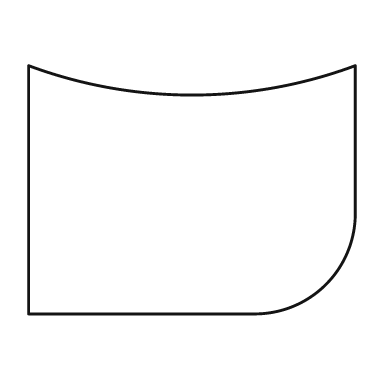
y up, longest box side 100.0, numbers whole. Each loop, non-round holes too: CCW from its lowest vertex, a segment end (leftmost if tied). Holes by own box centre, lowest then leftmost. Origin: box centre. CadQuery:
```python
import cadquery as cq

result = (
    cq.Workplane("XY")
    .moveTo(-50.0, -38.0)
    .lineTo(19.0, -38.0)
    .threePointArc((41.0, -29.0), (50.0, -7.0))
    .lineTo(50.0, 38.0)
    .threePointArc((0.0, 29.0), (-50.0, 38.0))
    .close()
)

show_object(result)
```